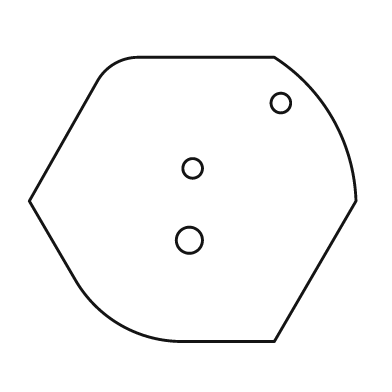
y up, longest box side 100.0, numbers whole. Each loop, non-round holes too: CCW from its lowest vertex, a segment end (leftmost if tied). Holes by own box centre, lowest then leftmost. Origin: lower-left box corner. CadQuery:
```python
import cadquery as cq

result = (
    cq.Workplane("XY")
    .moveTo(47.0, 0.0)
    .lineTo(75.0, 0.0)
    .lineTo(100.0, 43.0)
    .threePointArc((93.0, 68.0), (75.0, 87.0))
    .lineTo(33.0, 87.0)
    .threePointArc((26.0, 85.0), (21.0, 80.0))
    .lineTo(0.0, 43.0)
    .lineTo(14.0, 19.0)
    .threePointArc((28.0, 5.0), (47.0, 0.0))
    .close()
    .moveTo(49.0, 31.0)
    .circle(4.0)
    .moveTo(50.0, 53.0)
    .circle(3.0)
    .moveTo(77.0, 73.0)
    .circle(3.0)
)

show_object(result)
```